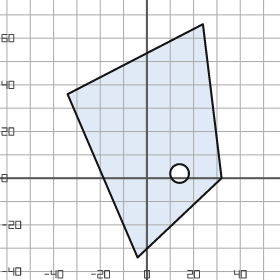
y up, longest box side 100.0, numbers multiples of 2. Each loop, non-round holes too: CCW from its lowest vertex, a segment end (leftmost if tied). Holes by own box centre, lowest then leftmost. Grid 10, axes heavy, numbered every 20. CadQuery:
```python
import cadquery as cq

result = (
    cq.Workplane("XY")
    .moveTo(-4.0, -34.0)
    .lineTo(32.0, 0.0)
    .lineTo(24.0, 66.0)
    .lineTo(-34.0, 36.0)
    .close()
    .moveTo(14.0, 2.0)
    .circle(4.0)
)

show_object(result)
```